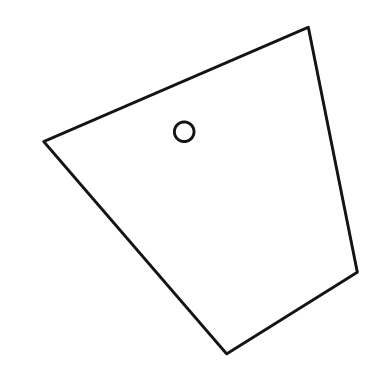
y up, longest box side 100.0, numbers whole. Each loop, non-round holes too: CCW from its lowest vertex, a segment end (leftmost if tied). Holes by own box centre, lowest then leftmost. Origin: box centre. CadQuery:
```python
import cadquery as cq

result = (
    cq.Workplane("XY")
    .moveTo(8.0, -50.0)
    .lineTo(48.0, -25.0)
    .lineTo(33.0, 50.0)
    .lineTo(-48.0, 15.0)
    .close()
    .moveTo(-5.0, 18.0)
    .circle(3.0)
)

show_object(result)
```